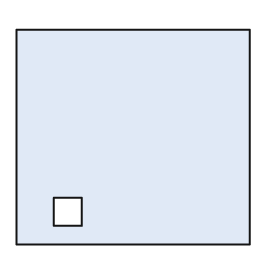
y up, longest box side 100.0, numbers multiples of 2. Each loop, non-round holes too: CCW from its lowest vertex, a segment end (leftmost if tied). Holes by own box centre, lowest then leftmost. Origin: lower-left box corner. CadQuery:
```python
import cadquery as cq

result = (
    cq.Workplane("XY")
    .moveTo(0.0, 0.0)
    .lineTo(100.0, 0.0)
    .lineTo(100.0, 92.0)
    .lineTo(0.0, 92.0)
    .close()
    .moveTo(16.0, 8.0)
    .lineTo(28.0, 8.0)
    .lineTo(28.0, 20.0)
    .lineTo(16.0, 20.0)
    .close()
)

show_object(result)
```